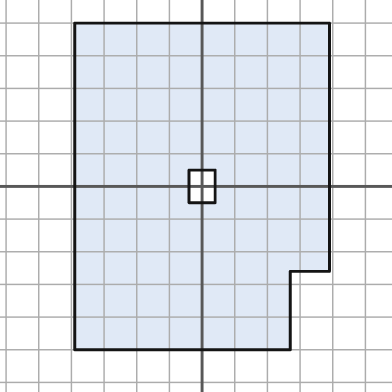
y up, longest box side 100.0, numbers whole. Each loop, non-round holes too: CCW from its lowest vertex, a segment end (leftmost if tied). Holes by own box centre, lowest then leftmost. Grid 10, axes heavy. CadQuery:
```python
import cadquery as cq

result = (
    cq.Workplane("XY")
    .moveTo(-39.0, -50.0)
    .lineTo(27.0, -50.0)
    .lineTo(27.0, -26.0)
    .lineTo(39.0, -26.0)
    .lineTo(39.0, 50.0)
    .lineTo(-39.0, 50.0)
    .close()
    .moveTo(-4.0, -5.0)
    .lineTo(4.0, -5.0)
    .lineTo(4.0, 5.0)
    .lineTo(-4.0, 5.0)
    .close()
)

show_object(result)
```